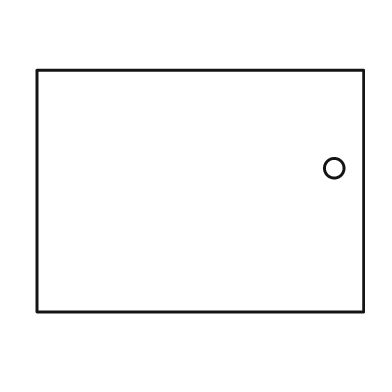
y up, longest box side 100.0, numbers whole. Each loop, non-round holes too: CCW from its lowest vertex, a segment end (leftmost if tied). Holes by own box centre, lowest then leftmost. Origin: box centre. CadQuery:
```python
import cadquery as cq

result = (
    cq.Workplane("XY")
    .moveTo(-50.0, -37.0)
    .lineTo(50.0, -37.0)
    .lineTo(50.0, 37.0)
    .lineTo(-50.0, 37.0)
    .close()
    .moveTo(41.0, 7.0)
    .circle(3.0)
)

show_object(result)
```